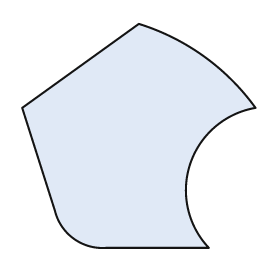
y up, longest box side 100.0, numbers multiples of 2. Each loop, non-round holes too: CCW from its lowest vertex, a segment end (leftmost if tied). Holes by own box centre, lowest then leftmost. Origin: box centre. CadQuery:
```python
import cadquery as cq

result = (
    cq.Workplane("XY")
    .moveTo(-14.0, -48.0)
    .lineTo(30.0, -48.0)
    .threePointArc((22.0, -12.0), (50.0, 12.0))
    .threePointArc((28.0, 34.0), (0.0, 48.0))
    .lineTo(-50.0, 12.0)
    .lineTo(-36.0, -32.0)
    .threePointArc((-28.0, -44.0), (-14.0, -48.0))
    .close()
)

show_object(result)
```